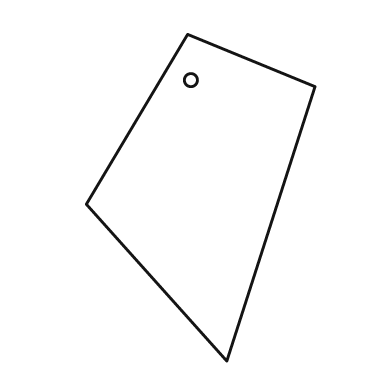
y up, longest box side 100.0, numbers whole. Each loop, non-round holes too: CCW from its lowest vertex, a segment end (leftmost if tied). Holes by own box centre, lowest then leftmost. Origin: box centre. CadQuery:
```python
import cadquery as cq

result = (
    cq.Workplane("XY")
    .moveTo(8.0, -50.0)
    .lineTo(35.0, 34.0)
    .lineTo(-4.0, 50.0)
    .lineTo(-35.0, -2.0)
    .close()
    .moveTo(-3.0, 36.0)
    .circle(2.0)
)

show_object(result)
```